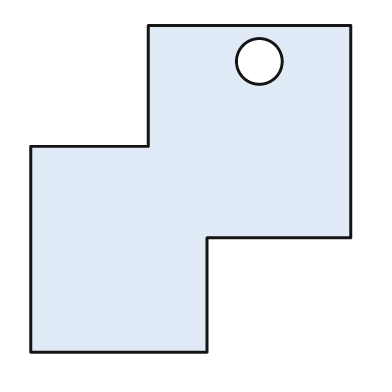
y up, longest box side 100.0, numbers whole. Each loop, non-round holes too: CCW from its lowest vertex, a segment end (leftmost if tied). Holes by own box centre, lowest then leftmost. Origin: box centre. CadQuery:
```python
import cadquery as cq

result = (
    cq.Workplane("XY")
    .moveTo(-49.0, -50.0)
    .lineTo(5.0, -50.0)
    .lineTo(5.0, -15.0)
    .lineTo(49.0, -15.0)
    .lineTo(49.0, 50.0)
    .lineTo(-13.0, 50.0)
    .lineTo(-13.0, 13.0)
    .lineTo(-49.0, 13.0)
    .close()
    .moveTo(21.0, 39.0)
    .circle(7.0)
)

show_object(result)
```